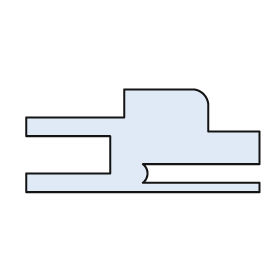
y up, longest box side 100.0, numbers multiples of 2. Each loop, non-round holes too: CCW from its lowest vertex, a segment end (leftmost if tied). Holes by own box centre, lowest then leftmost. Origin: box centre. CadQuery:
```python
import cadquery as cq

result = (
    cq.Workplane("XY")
    .moveTo(-50.0, -22.0)
    .lineTo(50.0, -22.0)
    .lineTo(50.0, -18.0)
    .lineTo(0.0, -18.0)
    .threePointArc((2.0, -14.0), (0.0, -10.0))
    .lineTo(50.0, -10.0)
    .lineTo(50.0, 4.0)
    .lineTo(28.0, 4.0)
    .lineTo(28.0, 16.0)
    .threePointArc((26.0, 20.0), (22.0, 22.0))
    .lineTo(-8.0, 22.0)
    .lineTo(-8.0, 10.0)
    .lineTo(-50.0, 10.0)
    .lineTo(-50.0, 2.0)
    .lineTo(-14.0, 2.0)
    .lineTo(-14.0, -14.0)
    .lineTo(-50.0, -14.0)
    .close()
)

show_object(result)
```